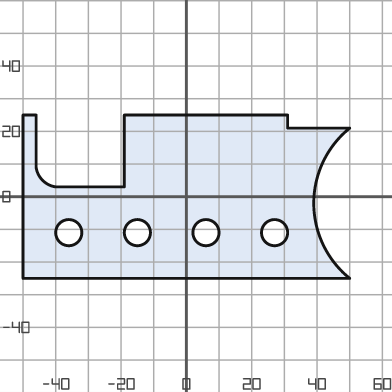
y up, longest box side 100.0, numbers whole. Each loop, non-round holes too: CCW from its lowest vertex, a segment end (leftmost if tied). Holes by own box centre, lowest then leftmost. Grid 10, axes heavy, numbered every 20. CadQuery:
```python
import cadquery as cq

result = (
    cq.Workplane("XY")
    .moveTo(-50.0, -25.0)
    .lineTo(50.0, -25.0)
    .threePointArc((39.0, -2.0), (50.0, 21.0))
    .lineTo(31.0, 21.0)
    .lineTo(31.0, 25.0)
    .lineTo(-19.0, 25.0)
    .lineTo(-19.0, 3.0)
    .lineTo(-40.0, 3.0)
    .threePointArc((-44.0, 5.0), (-46.0, 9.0))
    .lineTo(-46.0, 25.0)
    .lineTo(-50.0, 25.0)
    .close()
    .moveTo(-36.0, -11.0)
    .circle(4.0)
    .moveTo(-15.0, -11.0)
    .circle(4.0)
    .moveTo(6.0, -11.0)
    .circle(4.0)
    .moveTo(27.0, -11.0)
    .circle(4.0)
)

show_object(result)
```